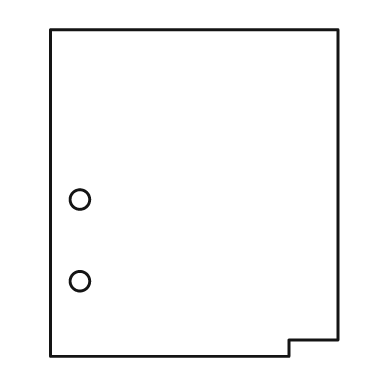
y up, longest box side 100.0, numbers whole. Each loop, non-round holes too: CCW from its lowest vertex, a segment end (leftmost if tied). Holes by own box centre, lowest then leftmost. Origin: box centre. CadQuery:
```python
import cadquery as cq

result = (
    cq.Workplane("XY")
    .moveTo(-44.0, -50.0)
    .lineTo(29.0, -50.0)
    .lineTo(29.0, -45.0)
    .lineTo(44.0, -45.0)
    .lineTo(44.0, 50.0)
    .lineTo(-44.0, 50.0)
    .close()
    .moveTo(-35.0, -27.0)
    .circle(3.0)
    .moveTo(-35.0, -2.0)
    .circle(3.0)
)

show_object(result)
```